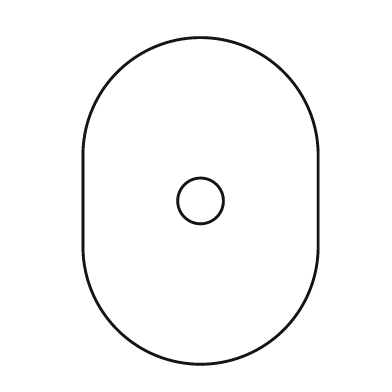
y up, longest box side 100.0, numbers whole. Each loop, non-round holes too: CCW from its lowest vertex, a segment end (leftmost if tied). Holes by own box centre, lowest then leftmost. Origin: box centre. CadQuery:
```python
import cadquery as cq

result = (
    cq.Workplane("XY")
    .moveTo(-36.0, -14.0)
    .threePointArc((0.0, -50.0), (36.0, -14.0))
    .lineTo(36.0, 14.0)
    .threePointArc((0.0, 50.0), (-36.0, 14.0))
    .close()
    .moveTo(0.0, 0.0)
    .circle(7.0)
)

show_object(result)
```